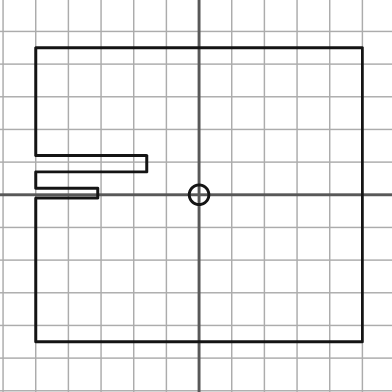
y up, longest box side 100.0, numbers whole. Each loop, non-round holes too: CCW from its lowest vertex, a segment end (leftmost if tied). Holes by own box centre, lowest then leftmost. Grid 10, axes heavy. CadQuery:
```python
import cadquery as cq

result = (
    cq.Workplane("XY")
    .moveTo(-50.0, -45.0)
    .lineTo(50.0, -45.0)
    .lineTo(50.0, 45.0)
    .lineTo(-50.0, 45.0)
    .lineTo(-50.0, 12.0)
    .lineTo(-16.0, 12.0)
    .lineTo(-16.0, 7.0)
    .lineTo(-50.0, 7.0)
    .lineTo(-50.0, 2.0)
    .lineTo(-31.0, 2.0)
    .lineTo(-31.0, -1.0)
    .lineTo(-50.0, -1.0)
    .close()
    .moveTo(0.0, 0.0)
    .circle(3.0)
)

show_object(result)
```